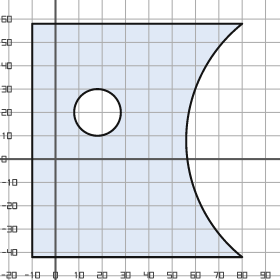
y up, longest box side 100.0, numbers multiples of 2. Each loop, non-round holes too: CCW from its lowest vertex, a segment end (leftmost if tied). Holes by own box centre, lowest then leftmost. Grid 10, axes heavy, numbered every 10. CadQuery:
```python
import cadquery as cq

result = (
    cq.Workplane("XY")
    .moveTo(-10.0, -42.0)
    .lineTo(80.0, -42.0)
    .threePointArc((56.0, 8.0), (80.0, 58.0))
    .lineTo(-10.0, 58.0)
    .close()
    .moveTo(18.0, 20.0)
    .circle(10.0)
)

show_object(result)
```